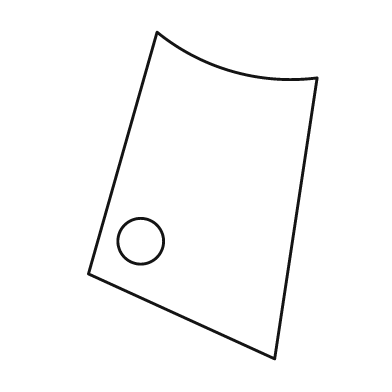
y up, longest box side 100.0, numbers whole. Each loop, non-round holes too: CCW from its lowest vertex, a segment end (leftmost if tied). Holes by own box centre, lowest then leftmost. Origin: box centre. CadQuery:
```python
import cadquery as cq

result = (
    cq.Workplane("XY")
    .moveTo(22.0, -50.0)
    .lineTo(35.0, 36.0)
    .threePointArc((9.0, 38.0), (-14.0, 50.0))
    .lineTo(-35.0, -24.0)
    .close()
    .moveTo(-19.0, -14.0)
    .circle(7.0)
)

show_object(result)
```